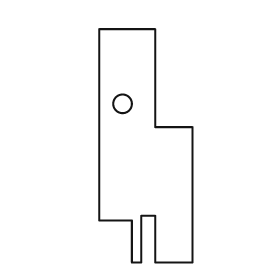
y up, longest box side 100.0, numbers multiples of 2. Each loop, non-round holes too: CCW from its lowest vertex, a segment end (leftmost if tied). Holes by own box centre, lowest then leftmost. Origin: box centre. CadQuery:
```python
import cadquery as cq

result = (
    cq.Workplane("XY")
    .moveTo(-6.0, -50.0)
    .lineTo(-2.0, -50.0)
    .lineTo(-2.0, -30.0)
    .lineTo(4.0, -30.0)
    .lineTo(4.0, -50.0)
    .lineTo(20.0, -50.0)
    .lineTo(20.0, 8.0)
    .lineTo(4.0, 8.0)
    .lineTo(4.0, 50.0)
    .lineTo(-20.0, 50.0)
    .lineTo(-20.0, -32.0)
    .lineTo(-6.0, -32.0)
    .close()
    .moveTo(-10.0, 18.0)
    .circle(4.0)
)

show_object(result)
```